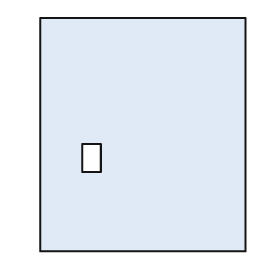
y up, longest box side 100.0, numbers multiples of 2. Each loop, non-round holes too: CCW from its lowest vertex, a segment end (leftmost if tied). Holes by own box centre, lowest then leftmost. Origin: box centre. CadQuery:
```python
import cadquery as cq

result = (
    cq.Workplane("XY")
    .moveTo(-44.0, -50.0)
    .lineTo(44.0, -50.0)
    .lineTo(44.0, 50.0)
    .lineTo(-44.0, 50.0)
    .close()
    .moveTo(-26.0, -16.0)
    .lineTo(-18.0, -16.0)
    .lineTo(-18.0, -4.0)
    .lineTo(-26.0, -4.0)
    .close()
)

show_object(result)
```